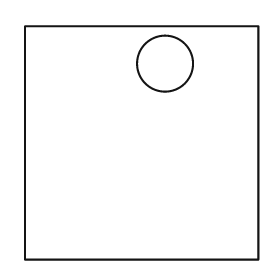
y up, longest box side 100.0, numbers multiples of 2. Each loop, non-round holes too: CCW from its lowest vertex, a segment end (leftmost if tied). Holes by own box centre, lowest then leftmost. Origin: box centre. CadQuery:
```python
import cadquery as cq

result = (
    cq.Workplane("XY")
    .moveTo(-50.0, -50.0)
    .lineTo(50.0, -50.0)
    .lineTo(50.0, 50.0)
    .lineTo(-50.0, 50.0)
    .close()
    .moveTo(10.0, 34.0)
    .circle(12.0)
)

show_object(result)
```